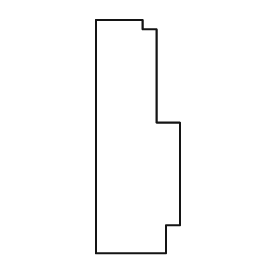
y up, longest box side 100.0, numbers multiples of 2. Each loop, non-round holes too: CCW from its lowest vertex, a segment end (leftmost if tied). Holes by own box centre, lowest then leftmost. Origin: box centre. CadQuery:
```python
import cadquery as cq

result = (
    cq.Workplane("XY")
    .moveTo(-18.0, -50.0)
    .lineTo(12.0, -50.0)
    .lineTo(12.0, -38.0)
    .lineTo(18.0, -38.0)
    .lineTo(18.0, 6.0)
    .lineTo(8.0, 6.0)
    .lineTo(8.0, 46.0)
    .lineTo(2.0, 46.0)
    .lineTo(2.0, 50.0)
    .lineTo(-18.0, 50.0)
    .close()
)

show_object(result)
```